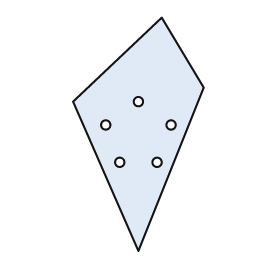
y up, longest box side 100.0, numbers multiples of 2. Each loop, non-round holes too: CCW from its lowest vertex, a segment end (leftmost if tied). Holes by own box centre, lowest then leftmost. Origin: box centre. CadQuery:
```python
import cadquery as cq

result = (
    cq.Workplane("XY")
    .moveTo(0.0, -50.0)
    .lineTo(28.0, 20.0)
    .lineTo(10.0, 50.0)
    .lineTo(-28.0, 14.0)
    .close()
    .moveTo(-8.0, -12.0)
    .circle(2.0)
    .moveTo(8.0, -12.0)
    .circle(2.0)
    .moveTo(-14.0, 4.0)
    .circle(2.0)
    .moveTo(14.0, 4.0)
    .circle(2.0)
    .moveTo(0.0, 14.0)
    .circle(2.0)
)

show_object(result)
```